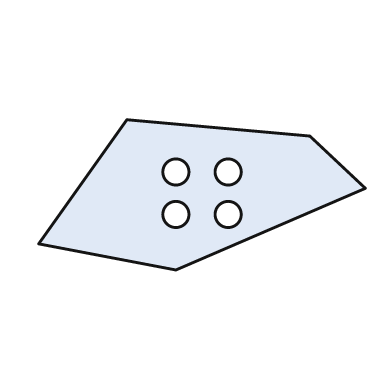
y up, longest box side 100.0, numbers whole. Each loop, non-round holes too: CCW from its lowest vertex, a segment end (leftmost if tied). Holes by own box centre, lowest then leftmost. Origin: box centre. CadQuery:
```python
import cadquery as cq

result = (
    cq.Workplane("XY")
    .moveTo(-8.0, -23.0)
    .lineTo(50.0, 2.0)
    .lineTo(33.0, 18.0)
    .lineTo(-23.0, 23.0)
    .lineTo(-50.0, -15.0)
    .close()
    .moveTo(-8.0, -6.0)
    .circle(4.0)
    .moveTo(8.0, -6.0)
    .circle(4.0)
    .moveTo(-8.0, 7.0)
    .circle(4.0)
    .moveTo(8.0, 7.0)
    .circle(4.0)
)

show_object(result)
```